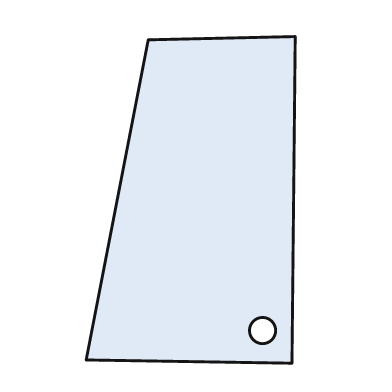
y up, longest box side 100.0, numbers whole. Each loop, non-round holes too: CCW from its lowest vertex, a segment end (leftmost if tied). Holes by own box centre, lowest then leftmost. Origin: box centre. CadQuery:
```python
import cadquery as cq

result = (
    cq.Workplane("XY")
    .moveTo(31.0, -50.0)
    .lineTo(32.0, 50.0)
    .lineTo(-13.0, 49.0)
    .lineTo(-32.0, -49.0)
    .close()
    .moveTo(22.0, -40.0)
    .circle(4.0)
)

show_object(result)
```